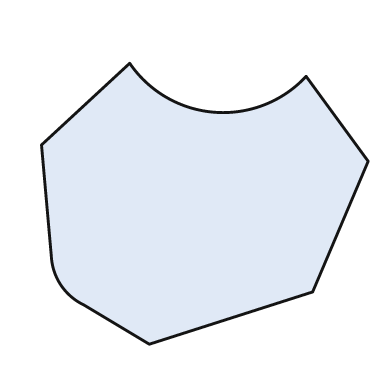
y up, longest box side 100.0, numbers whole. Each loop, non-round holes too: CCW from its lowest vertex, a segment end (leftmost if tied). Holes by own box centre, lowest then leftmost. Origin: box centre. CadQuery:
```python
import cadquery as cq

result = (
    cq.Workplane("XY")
    .moveTo(-17.0, -43.0)
    .lineTo(33.0, -27.0)
    .lineTo(50.0, 13.0)
    .lineTo(31.0, 39.0)
    .threePointArc((3.0, 28.0), (-23.0, 43.0))
    .lineTo(-50.0, 18.0)
    .lineTo(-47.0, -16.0)
    .threePointArc((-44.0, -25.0), (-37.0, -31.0))
    .close()
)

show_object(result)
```